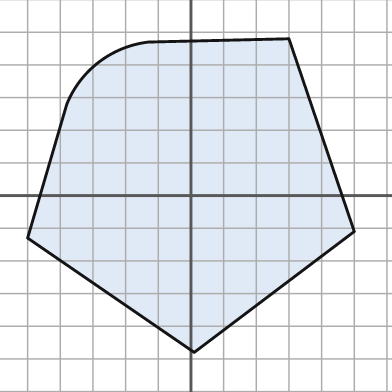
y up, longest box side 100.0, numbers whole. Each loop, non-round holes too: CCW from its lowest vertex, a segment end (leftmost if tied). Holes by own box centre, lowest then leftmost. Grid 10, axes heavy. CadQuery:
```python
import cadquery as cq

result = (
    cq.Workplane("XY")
    .moveTo(1.0, -48.0)
    .lineTo(50.0, -11.0)
    .lineTo(30.0, 48.0)
    .lineTo(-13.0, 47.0)
    .threePointArc((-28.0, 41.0), (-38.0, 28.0))
    .lineTo(-50.0, -13.0)
    .close()
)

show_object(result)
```